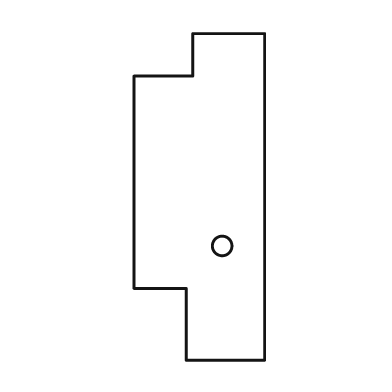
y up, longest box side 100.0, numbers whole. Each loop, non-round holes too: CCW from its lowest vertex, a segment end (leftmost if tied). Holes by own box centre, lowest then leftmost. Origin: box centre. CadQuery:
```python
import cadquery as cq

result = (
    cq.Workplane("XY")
    .moveTo(-4.0, -50.0)
    .lineTo(20.0, -50.0)
    .lineTo(20.0, 50.0)
    .lineTo(-2.0, 50.0)
    .lineTo(-2.0, 37.0)
    .lineTo(-20.0, 37.0)
    .lineTo(-20.0, -28.0)
    .lineTo(-4.0, -28.0)
    .close()
    .moveTo(7.0, -15.0)
    .circle(3.0)
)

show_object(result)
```